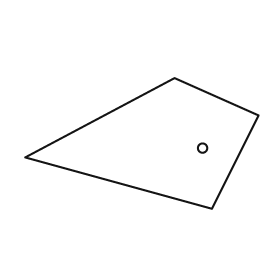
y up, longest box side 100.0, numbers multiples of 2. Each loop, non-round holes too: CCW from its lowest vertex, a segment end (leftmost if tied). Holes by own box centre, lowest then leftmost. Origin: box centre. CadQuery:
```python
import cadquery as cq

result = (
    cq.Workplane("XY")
    .moveTo(30.0, -28.0)
    .lineTo(50.0, 12.0)
    .lineTo(14.0, 28.0)
    .lineTo(-50.0, -6.0)
    .close()
    .moveTo(26.0, -2.0)
    .circle(2.0)
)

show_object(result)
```